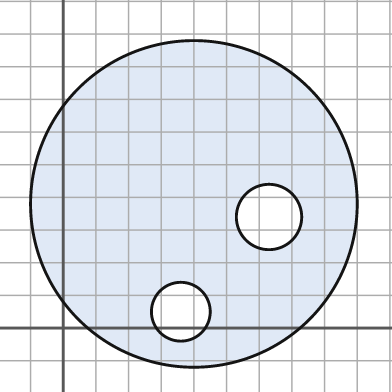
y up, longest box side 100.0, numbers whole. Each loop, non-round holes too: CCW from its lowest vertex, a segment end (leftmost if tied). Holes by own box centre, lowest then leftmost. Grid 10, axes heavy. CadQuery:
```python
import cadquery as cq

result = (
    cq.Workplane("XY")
    .moveTo(40.0, 38.0)
    .circle(50.0)
    .moveTo(36.0, 5.0)
    .circle(9.0)
    .moveTo(63.0, 34.0)
    .circle(10.0)
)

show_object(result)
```